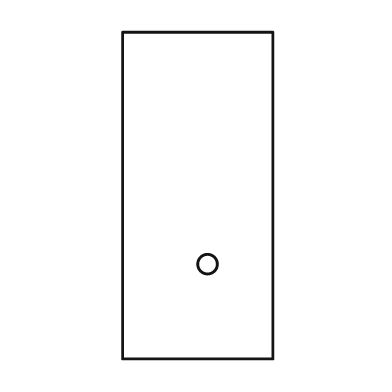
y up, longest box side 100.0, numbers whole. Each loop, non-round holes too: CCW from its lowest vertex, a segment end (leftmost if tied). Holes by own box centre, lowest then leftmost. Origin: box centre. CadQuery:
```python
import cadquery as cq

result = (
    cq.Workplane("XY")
    .moveTo(-23.0, -50.0)
    .lineTo(23.0, -50.0)
    .lineTo(23.0, 50.0)
    .lineTo(-23.0, 50.0)
    .close()
    .moveTo(3.0, -21.0)
    .circle(3.0)
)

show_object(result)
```